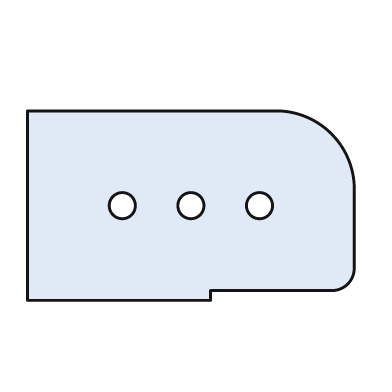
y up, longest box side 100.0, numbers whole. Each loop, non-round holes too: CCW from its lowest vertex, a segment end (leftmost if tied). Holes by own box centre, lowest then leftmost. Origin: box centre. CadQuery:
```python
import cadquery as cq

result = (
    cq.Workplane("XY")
    .moveTo(-50.0, -29.0)
    .lineTo(6.0, -29.0)
    .lineTo(6.0, -26.0)
    .lineTo(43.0, -26.0)
    .threePointArc((48.0, -24.0), (50.0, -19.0))
    .lineTo(50.0, 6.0)
    .threePointArc((43.0, 22.0), (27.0, 29.0))
    .lineTo(-50.0, 29.0)
    .close()
    .moveTo(-21.0, 0.0)
    .circle(4.0)
    .moveTo(0.0, 0.0)
    .circle(4.0)
    .moveTo(21.0, 0.0)
    .circle(4.0)
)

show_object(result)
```